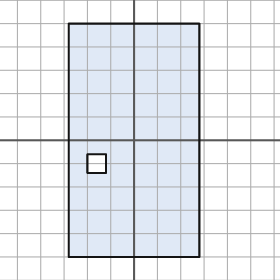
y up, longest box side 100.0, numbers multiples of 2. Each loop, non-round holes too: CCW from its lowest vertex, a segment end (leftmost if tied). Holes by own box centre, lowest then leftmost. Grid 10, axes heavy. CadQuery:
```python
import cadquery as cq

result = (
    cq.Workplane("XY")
    .moveTo(-28.0, -50.0)
    .lineTo(28.0, -50.0)
    .lineTo(28.0, 50.0)
    .lineTo(-28.0, 50.0)
    .close()
    .moveTo(-20.0, -14.0)
    .lineTo(-12.0, -14.0)
    .lineTo(-12.0, -6.0)
    .lineTo(-20.0, -6.0)
    .close()
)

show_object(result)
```